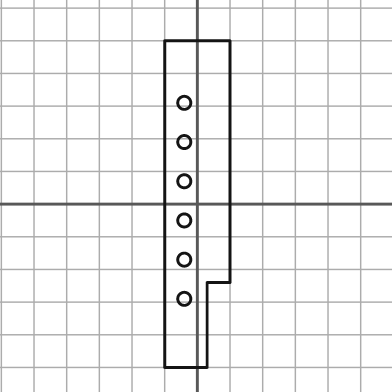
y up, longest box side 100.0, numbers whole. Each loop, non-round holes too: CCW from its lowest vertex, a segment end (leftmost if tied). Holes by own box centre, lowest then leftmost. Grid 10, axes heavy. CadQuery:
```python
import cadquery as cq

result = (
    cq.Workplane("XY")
    .moveTo(-10.0, -50.0)
    .lineTo(3.0, -50.0)
    .lineTo(3.0, -24.0)
    .lineTo(10.0, -24.0)
    .lineTo(10.0, 50.0)
    .lineTo(-10.0, 50.0)
    .close()
    .moveTo(-4.0, -29.0)
    .circle(2.0)
    .moveTo(-4.0, -17.0)
    .circle(2.0)
    .moveTo(-4.0, -5.0)
    .circle(2.0)
    .moveTo(-4.0, 7.0)
    .circle(2.0)
    .moveTo(-4.0, 19.0)
    .circle(2.0)
    .moveTo(-4.0, 31.0)
    .circle(2.0)
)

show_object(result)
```